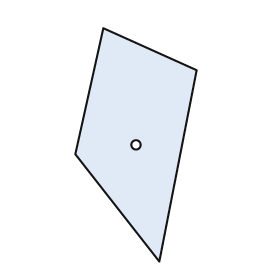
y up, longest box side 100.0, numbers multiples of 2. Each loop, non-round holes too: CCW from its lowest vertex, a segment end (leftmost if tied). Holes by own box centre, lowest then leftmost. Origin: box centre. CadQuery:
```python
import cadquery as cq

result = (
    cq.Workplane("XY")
    .moveTo(10.0, -50.0)
    .lineTo(26.0, 32.0)
    .lineTo(-14.0, 50.0)
    .lineTo(-26.0, -4.0)
    .close()
    .moveTo(0.0, 0.0)
    .circle(2.0)
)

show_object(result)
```